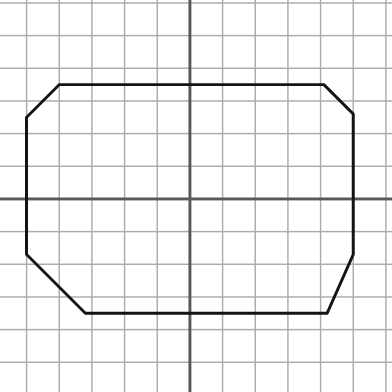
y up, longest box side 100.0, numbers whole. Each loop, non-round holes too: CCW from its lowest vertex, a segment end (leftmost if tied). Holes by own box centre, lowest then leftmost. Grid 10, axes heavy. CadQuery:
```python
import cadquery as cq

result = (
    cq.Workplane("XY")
    .moveTo(-32.0, -35.0)
    .lineTo(42.0, -35.0)
    .lineTo(50.0, -17.0)
    .lineTo(50.0, 26.0)
    .lineTo(41.0, 35.0)
    .lineTo(-40.0, 35.0)
    .lineTo(-50.0, 25.0)
    .lineTo(-50.0, -17.0)
    .close()
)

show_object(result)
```